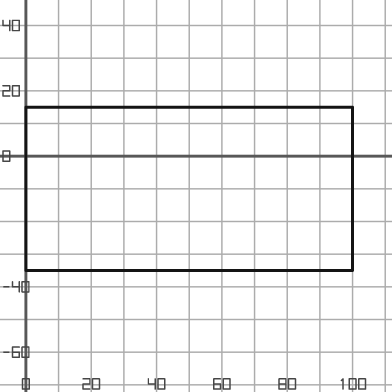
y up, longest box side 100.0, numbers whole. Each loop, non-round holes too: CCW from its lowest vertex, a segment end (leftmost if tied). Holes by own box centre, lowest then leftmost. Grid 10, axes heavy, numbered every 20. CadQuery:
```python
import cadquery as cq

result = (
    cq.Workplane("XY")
    .moveTo(0.0, -35.0)
    .lineTo(100.0, -35.0)
    .lineTo(100.0, 15.0)
    .lineTo(0.0, 15.0)
    .close()
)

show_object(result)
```